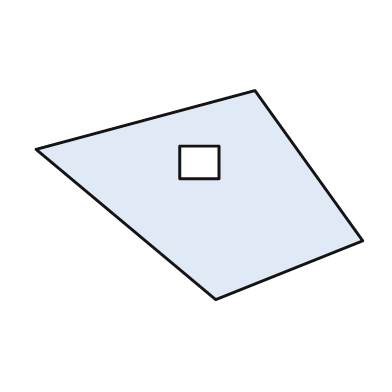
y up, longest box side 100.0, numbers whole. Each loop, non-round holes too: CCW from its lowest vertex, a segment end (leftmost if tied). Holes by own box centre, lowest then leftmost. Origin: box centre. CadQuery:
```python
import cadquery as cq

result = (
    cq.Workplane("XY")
    .moveTo(5.0, -32.0)
    .lineTo(50.0, -14.0)
    .lineTo(17.0, 32.0)
    .lineTo(-50.0, 14.0)
    .close()
    .moveTo(-6.0, 5.0)
    .lineTo(6.0, 5.0)
    .lineTo(6.0, 15.0)
    .lineTo(-6.0, 15.0)
    .close()
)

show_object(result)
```